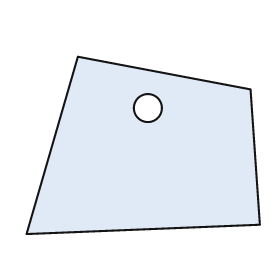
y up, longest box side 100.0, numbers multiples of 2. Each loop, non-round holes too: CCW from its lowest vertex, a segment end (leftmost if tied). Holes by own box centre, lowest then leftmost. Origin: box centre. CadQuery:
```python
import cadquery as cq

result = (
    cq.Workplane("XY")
    .moveTo(-50.0, -38.0)
    .lineTo(50.0, -34.0)
    .lineTo(46.0, 24.0)
    .lineTo(-28.0, 38.0)
    .close()
    .moveTo(2.0, 16.0)
    .circle(6.0)
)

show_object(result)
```